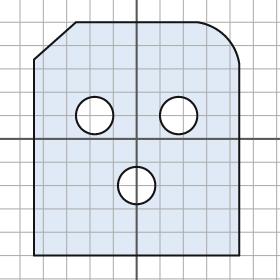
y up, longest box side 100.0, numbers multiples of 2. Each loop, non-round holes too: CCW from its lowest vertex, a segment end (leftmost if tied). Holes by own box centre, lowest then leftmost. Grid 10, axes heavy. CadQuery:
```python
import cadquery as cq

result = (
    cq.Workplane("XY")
    .moveTo(-44.0, -50.0)
    .lineTo(44.0, -50.0)
    .lineTo(44.0, 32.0)
    .threePointArc((38.0, 44.0), (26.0, 50.0))
    .lineTo(-26.0, 50.0)
    .lineTo(-44.0, 34.0)
    .close()
    .moveTo(0.0, -20.0)
    .circle(8.0)
    .moveTo(-18.0, 10.0)
    .circle(8.0)
    .moveTo(18.0, 10.0)
    .circle(8.0)
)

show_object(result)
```